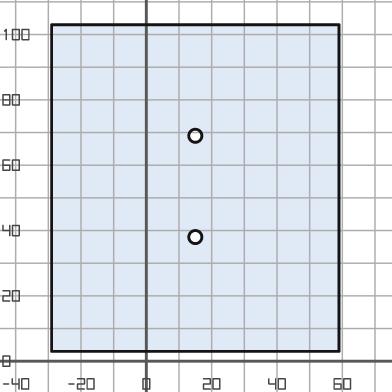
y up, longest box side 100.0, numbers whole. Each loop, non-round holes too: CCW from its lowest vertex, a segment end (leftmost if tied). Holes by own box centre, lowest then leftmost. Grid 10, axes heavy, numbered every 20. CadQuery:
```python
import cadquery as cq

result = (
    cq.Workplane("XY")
    .moveTo(-29.0, 3.0)
    .lineTo(59.0, 3.0)
    .lineTo(59.0, 103.0)
    .lineTo(-29.0, 103.0)
    .close()
    .moveTo(15.0, 38.0)
    .circle(2.0)
    .moveTo(15.0, 69.0)
    .circle(2.0)
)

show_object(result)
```